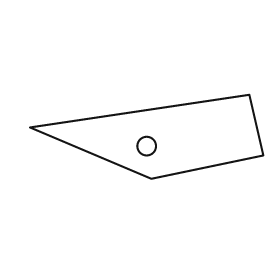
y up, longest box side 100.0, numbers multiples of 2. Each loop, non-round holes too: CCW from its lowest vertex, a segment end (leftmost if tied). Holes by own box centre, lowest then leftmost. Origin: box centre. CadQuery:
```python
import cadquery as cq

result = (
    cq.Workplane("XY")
    .moveTo(2.0, -18.0)
    .lineTo(50.0, -8.0)
    .lineTo(44.0, 18.0)
    .lineTo(-50.0, 4.0)
    .close()
    .moveTo(0.0, -4.0)
    .circle(4.0)
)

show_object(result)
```